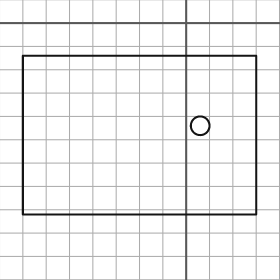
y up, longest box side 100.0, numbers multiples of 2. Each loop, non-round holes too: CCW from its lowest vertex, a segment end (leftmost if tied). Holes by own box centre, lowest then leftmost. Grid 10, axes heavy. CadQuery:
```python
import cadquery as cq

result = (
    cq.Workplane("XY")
    .moveTo(-70.0, -82.0)
    .lineTo(30.0, -82.0)
    .lineTo(30.0, -14.0)
    .lineTo(-70.0, -14.0)
    .close()
    .moveTo(6.0, -44.0)
    .circle(4.0)
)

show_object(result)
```